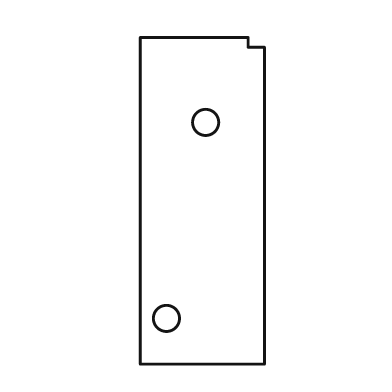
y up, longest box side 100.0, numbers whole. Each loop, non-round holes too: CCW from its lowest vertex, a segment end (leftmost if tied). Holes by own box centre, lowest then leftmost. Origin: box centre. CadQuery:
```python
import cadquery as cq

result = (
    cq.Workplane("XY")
    .moveTo(-19.0, -50.0)
    .lineTo(19.0, -50.0)
    .lineTo(19.0, 47.0)
    .lineTo(14.0, 47.0)
    .lineTo(14.0, 50.0)
    .lineTo(-19.0, 50.0)
    .close()
    .moveTo(-11.0, -36.0)
    .circle(4.0)
    .moveTo(1.0, 24.0)
    .circle(4.0)
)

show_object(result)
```